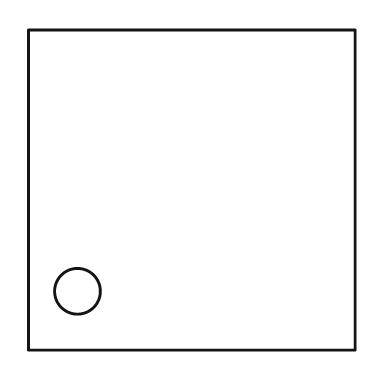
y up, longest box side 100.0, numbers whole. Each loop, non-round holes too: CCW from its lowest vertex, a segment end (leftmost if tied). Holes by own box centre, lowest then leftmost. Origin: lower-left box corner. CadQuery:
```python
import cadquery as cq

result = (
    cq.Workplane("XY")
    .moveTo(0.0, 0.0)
    .lineTo(100.0, 0.0)
    .lineTo(100.0, 98.0)
    .lineTo(0.0, 98.0)
    .close()
    .moveTo(15.0, 18.0)
    .circle(7.0)
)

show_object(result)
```